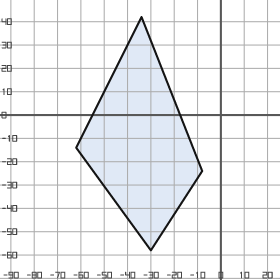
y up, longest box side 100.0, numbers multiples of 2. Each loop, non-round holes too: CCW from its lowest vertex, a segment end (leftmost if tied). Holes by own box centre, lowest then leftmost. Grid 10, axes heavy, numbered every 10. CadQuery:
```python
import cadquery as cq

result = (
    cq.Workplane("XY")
    .moveTo(-30.0, -58.0)
    .lineTo(-8.0, -24.0)
    .lineTo(-34.0, 42.0)
    .lineTo(-62.0, -14.0)
    .close()
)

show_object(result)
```